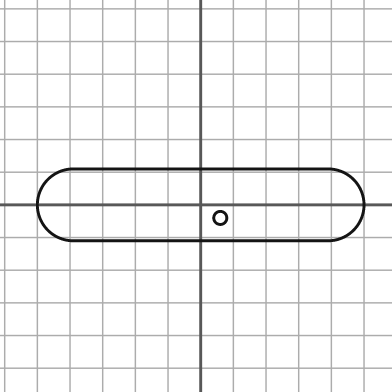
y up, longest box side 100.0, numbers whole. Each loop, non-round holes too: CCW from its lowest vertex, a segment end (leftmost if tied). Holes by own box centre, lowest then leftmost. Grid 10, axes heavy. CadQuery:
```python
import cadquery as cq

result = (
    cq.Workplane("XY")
    .moveTo(-39.0, -11.0)
    .lineTo(39.0, -11.0)
    .threePointArc((50.0, 0.0), (39.0, 11.0))
    .lineTo(-39.0, 11.0)
    .threePointArc((-50.0, 0.0), (-39.0, -11.0))
    .close()
    .moveTo(6.0, -4.0)
    .circle(2.0)
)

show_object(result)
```